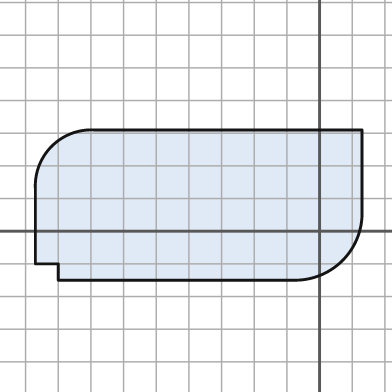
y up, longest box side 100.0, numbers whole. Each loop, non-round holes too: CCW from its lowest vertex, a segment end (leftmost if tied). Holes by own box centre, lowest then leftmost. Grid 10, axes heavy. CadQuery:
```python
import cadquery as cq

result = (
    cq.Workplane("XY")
    .moveTo(-80.0, -15.0)
    .lineTo(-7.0, -15.0)
    .threePointArc((7.0, -9.0), (13.0, 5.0))
    .lineTo(13.0, 31.0)
    .lineTo(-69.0, 31.0)
    .threePointArc((-82.0, 26.0), (-87.0, 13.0))
    .lineTo(-87.0, -10.0)
    .lineTo(-80.0, -10.0)
    .close()
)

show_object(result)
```